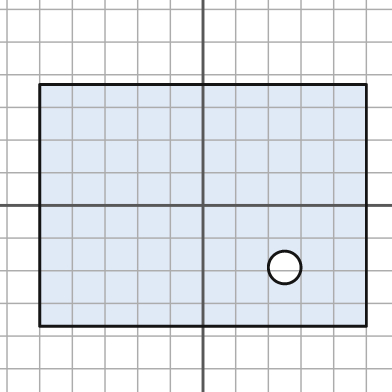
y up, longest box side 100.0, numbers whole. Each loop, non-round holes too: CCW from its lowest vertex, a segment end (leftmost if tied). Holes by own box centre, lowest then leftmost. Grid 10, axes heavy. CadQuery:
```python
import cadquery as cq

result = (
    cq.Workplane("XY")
    .moveTo(-50.0, -37.0)
    .lineTo(50.0, -37.0)
    .lineTo(50.0, 37.0)
    .lineTo(-50.0, 37.0)
    .close()
    .moveTo(25.0, -19.0)
    .circle(5.0)
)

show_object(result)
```